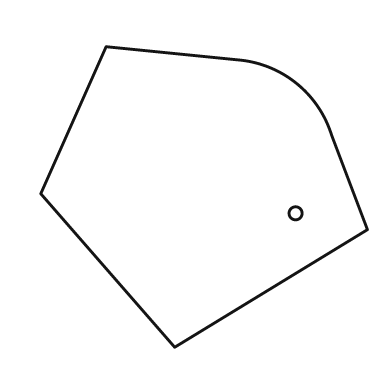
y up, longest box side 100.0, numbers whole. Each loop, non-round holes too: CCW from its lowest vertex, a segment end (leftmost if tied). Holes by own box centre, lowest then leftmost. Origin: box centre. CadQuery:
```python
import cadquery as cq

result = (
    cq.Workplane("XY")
    .moveTo(-9.0, -46.0)
    .lineTo(50.0, -10.0)
    .lineTo(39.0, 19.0)
    .threePointArc((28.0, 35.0), (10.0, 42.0))
    .lineTo(-30.0, 46.0)
    .lineTo(-50.0, 1.0)
    .close()
    .moveTo(28.0, -5.0)
    .circle(2.0)
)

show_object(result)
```